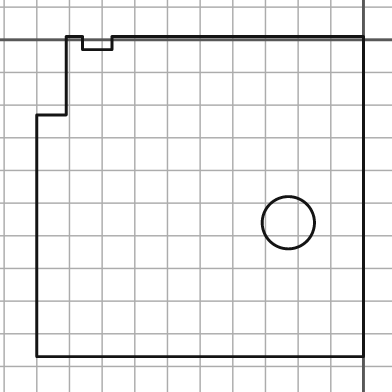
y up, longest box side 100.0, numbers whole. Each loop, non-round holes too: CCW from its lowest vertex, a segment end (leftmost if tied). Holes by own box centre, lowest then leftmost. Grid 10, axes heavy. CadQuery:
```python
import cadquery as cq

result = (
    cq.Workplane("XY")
    .moveTo(-100.0, -97.0)
    .lineTo(0.0, -97.0)
    .lineTo(0.0, 1.0)
    .lineTo(-77.0, 1.0)
    .lineTo(-77.0, -3.0)
    .lineTo(-86.0, -3.0)
    .lineTo(-86.0, 1.0)
    .lineTo(-91.0, 1.0)
    .lineTo(-91.0, -23.0)
    .lineTo(-100.0, -23.0)
    .close()
    .moveTo(-23.0, -56.0)
    .circle(8.0)
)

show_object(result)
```